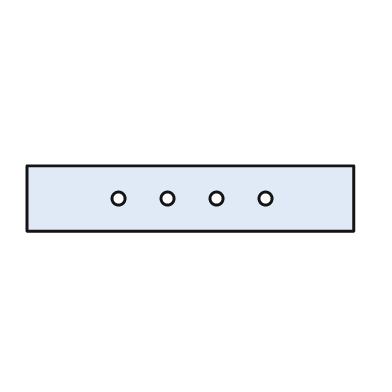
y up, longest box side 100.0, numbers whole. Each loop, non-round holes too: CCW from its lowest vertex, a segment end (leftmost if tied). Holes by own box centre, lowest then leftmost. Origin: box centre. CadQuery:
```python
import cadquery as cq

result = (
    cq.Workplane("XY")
    .moveTo(-50.0, -10.0)
    .lineTo(50.0, -10.0)
    .lineTo(50.0, 10.0)
    .lineTo(-50.0, 10.0)
    .close()
    .moveTo(-22.0, 0.0)
    .circle(2.0)
    .moveTo(-7.0, 0.0)
    .circle(2.0)
    .moveTo(8.0, 0.0)
    .circle(2.0)
    .moveTo(23.0, 0.0)
    .circle(2.0)
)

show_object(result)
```